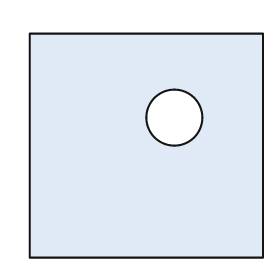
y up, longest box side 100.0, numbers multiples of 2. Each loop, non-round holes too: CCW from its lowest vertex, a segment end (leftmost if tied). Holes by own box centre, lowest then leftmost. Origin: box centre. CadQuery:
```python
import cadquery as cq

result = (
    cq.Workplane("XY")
    .moveTo(-50.0, -48.0)
    .lineTo(50.0, -48.0)
    .lineTo(50.0, 48.0)
    .lineTo(-50.0, 48.0)
    .close()
    .moveTo(12.0, 12.0)
    .circle(12.0)
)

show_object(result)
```